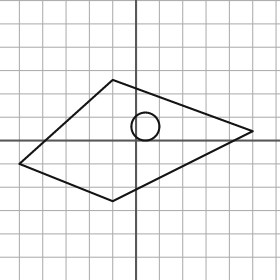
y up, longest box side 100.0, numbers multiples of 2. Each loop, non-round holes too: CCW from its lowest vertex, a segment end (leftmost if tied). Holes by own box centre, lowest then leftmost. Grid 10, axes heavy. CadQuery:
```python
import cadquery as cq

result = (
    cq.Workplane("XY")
    .moveTo(-10.0, -26.0)
    .lineTo(50.0, 4.0)
    .lineTo(-10.0, 26.0)
    .lineTo(-50.0, -10.0)
    .close()
    .moveTo(4.0, 6.0)
    .circle(6.0)
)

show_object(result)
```